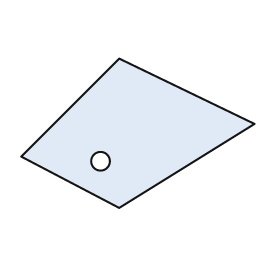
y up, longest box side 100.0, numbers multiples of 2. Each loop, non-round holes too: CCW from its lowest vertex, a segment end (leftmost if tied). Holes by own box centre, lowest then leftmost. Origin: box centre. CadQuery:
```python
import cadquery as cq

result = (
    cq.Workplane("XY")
    .moveTo(-8.0, -32.0)
    .lineTo(50.0, 4.0)
    .lineTo(-8.0, 32.0)
    .lineTo(-50.0, -10.0)
    .close()
    .moveTo(-16.0, -12.0)
    .circle(4.0)
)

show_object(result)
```